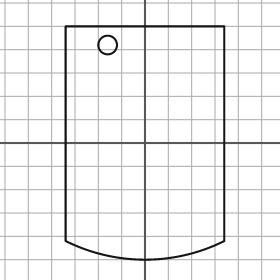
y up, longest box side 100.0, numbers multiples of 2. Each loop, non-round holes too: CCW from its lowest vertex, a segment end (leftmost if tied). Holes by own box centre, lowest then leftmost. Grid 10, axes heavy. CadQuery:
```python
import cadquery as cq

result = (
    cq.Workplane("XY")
    .moveTo(-34.0, -42.0)
    .threePointArc((0.0, -50.0), (34.0, -42.0))
    .lineTo(34.0, 50.0)
    .lineTo(-34.0, 50.0)
    .close()
    .moveTo(-16.0, 42.0)
    .circle(4.0)
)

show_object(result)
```